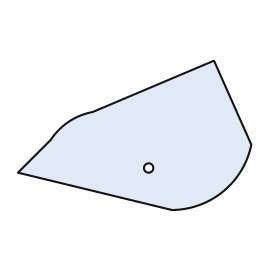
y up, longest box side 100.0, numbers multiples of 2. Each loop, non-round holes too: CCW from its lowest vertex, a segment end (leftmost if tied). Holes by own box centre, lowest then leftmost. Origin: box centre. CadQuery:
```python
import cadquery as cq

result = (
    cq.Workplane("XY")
    .moveTo(16.0, -32.0)
    .threePointArc((38.0, -24.0), (50.0, -4.0))
    .lineTo(34.0, 32.0)
    .lineTo(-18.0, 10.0)
    .threePointArc((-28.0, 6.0), (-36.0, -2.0))
    .lineTo(-50.0, -16.0)
    .close()
    .moveTo(6.0, -14.0)
    .circle(2.0)
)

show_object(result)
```